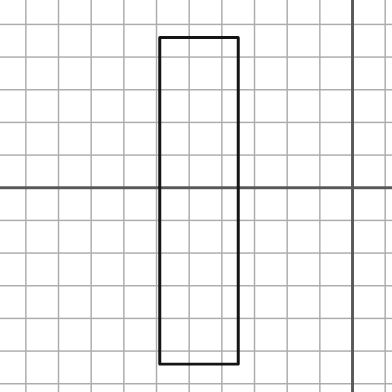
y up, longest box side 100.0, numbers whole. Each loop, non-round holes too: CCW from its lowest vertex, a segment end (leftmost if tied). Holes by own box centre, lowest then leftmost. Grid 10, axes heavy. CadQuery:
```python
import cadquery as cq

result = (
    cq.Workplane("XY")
    .moveTo(-59.0, -54.0)
    .lineTo(-35.0, -54.0)
    .lineTo(-35.0, 46.0)
    .lineTo(-59.0, 46.0)
    .close()
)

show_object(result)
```